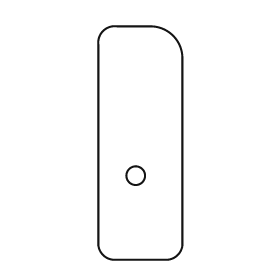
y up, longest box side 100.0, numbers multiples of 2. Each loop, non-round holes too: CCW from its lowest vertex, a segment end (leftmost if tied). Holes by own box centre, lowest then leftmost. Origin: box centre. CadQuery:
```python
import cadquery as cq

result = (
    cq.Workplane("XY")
    .moveTo(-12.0, -50.0)
    .lineTo(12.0, -50.0)
    .threePointArc((16.0, -48.0), (18.0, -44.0))
    .lineTo(18.0, 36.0)
    .threePointArc((14.0, 46.0), (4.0, 50.0))
    .lineTo(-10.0, 50.0)
    .threePointArc((-16.0, 48.0), (-18.0, 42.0))
    .lineTo(-18.0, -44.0)
    .threePointArc((-16.0, -48.0), (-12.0, -50.0))
    .close()
    .moveTo(-2.0, -14.0)
    .circle(4.0)
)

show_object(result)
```